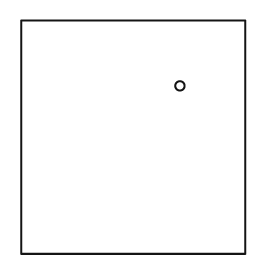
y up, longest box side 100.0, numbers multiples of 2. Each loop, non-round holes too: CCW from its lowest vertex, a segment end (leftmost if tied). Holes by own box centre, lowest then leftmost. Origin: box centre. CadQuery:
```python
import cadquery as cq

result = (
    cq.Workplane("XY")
    .moveTo(-48.0, -50.0)
    .lineTo(48.0, -50.0)
    .lineTo(48.0, 50.0)
    .lineTo(-48.0, 50.0)
    .close()
    .moveTo(20.0, 22.0)
    .circle(2.0)
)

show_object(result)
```